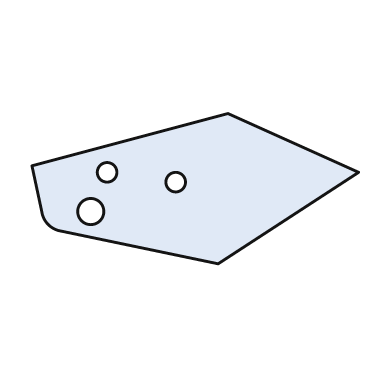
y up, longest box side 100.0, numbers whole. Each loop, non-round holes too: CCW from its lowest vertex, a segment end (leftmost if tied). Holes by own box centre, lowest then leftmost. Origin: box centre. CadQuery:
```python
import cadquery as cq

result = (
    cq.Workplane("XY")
    .moveTo(7.0, -23.0)
    .lineTo(50.0, 5.0)
    .lineTo(10.0, 23.0)
    .lineTo(-50.0, 7.0)
    .lineTo(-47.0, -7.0)
    .threePointArc((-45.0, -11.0), (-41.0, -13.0))
    .close()
    .moveTo(-32.0, -7.0)
    .circle(4.0)
    .moveTo(-6.0, 2.0)
    .circle(3.0)
    .moveTo(-27.0, 5.0)
    .circle(3.0)
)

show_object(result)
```